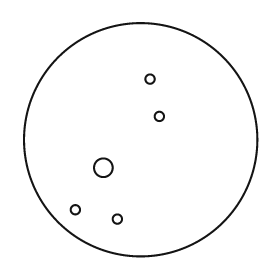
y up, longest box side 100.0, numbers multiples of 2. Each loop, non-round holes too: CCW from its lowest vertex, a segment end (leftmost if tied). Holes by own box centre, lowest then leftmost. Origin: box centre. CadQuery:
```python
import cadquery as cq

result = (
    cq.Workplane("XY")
    .moveTo(0.0, 0.0)
    .circle(50.0)
    .moveTo(-10.0, -34.0)
    .circle(2.0)
    .moveTo(-28.0, -30.0)
    .circle(2.0)
    .moveTo(-16.0, -12.0)
    .circle(4.0)
    .moveTo(8.0, 10.0)
    .circle(2.0)
    .moveTo(4.0, 26.0)
    .circle(2.0)
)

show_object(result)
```